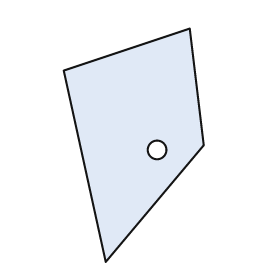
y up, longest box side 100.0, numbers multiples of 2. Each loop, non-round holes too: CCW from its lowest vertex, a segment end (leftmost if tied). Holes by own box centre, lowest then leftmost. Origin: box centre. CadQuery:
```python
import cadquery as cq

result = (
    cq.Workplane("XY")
    .moveTo(-12.0, -50.0)
    .lineTo(30.0, 0.0)
    .lineTo(24.0, 50.0)
    .lineTo(-30.0, 32.0)
    .close()
    .moveTo(10.0, -2.0)
    .circle(4.0)
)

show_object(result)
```